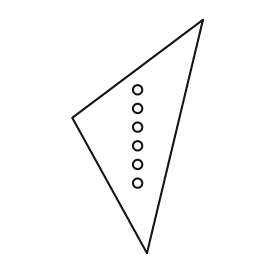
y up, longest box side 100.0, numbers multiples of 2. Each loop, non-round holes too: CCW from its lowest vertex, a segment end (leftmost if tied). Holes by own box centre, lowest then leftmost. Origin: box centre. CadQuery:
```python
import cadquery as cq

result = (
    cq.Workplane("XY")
    .moveTo(4.0, -50.0)
    .lineTo(28.0, 50.0)
    .lineTo(-28.0, 8.0)
    .close()
    .moveTo(0.0, -20.0)
    .circle(2.0)
    .moveTo(0.0, -12.0)
    .circle(2.0)
    .moveTo(0.0, -4.0)
    .circle(2.0)
    .moveTo(0.0, 4.0)
    .circle(2.0)
    .moveTo(0.0, 12.0)
    .circle(2.0)
    .moveTo(0.0, 20.0)
    .circle(2.0)
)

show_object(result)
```